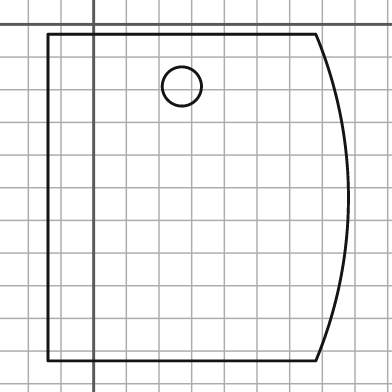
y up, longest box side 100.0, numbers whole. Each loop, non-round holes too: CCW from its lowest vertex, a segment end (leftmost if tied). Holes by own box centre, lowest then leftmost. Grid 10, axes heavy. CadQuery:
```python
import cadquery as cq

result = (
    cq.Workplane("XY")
    .moveTo(-14.0, -103.0)
    .lineTo(68.0, -103.0)
    .threePointArc((78.0, -53.0), (68.0, -3.0))
    .lineTo(-14.0, -3.0)
    .close()
    .moveTo(27.0, -19.0)
    .circle(6.0)
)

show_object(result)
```